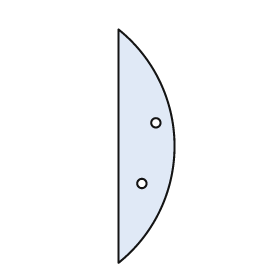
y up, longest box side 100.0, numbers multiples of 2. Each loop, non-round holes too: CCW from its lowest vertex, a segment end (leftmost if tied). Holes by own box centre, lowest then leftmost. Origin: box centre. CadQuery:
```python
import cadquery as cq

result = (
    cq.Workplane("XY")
    .moveTo(-12.0, -50.0)
    .threePointArc((12.0, 0.0), (-12.0, 50.0))
    .close()
    .moveTo(-2.0, -16.0)
    .circle(2.0)
    .moveTo(4.0, 10.0)
    .circle(2.0)
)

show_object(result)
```